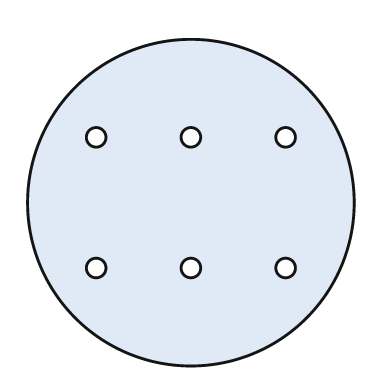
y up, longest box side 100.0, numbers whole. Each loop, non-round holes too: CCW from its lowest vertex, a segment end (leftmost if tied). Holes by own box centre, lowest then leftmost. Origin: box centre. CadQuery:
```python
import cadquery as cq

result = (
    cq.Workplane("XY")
    .moveTo(0.0, 0.0)
    .circle(50.0)
    .moveTo(-29.0, -20.0)
    .circle(3.0)
    .moveTo(0.0, -20.0)
    .circle(3.0)
    .moveTo(29.0, -20.0)
    .circle(3.0)
    .moveTo(-29.0, 20.0)
    .circle(3.0)
    .moveTo(0.0, 20.0)
    .circle(3.0)
    .moveTo(29.0, 20.0)
    .circle(3.0)
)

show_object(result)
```